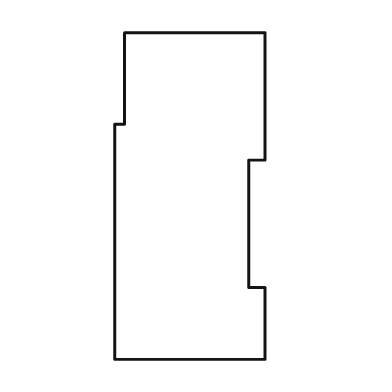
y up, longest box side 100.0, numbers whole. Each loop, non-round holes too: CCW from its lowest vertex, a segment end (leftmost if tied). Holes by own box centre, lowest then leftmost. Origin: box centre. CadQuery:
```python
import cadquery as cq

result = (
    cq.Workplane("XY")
    .moveTo(-23.0, -50.0)
    .lineTo(23.0, -50.0)
    .lineTo(23.0, -28.0)
    .lineTo(18.0, -28.0)
    .lineTo(18.0, 11.0)
    .lineTo(23.0, 11.0)
    .lineTo(23.0, 50.0)
    .lineTo(-20.0, 50.0)
    .lineTo(-20.0, 22.0)
    .lineTo(-23.0, 22.0)
    .close()
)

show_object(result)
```